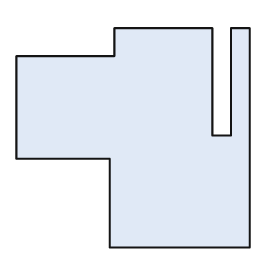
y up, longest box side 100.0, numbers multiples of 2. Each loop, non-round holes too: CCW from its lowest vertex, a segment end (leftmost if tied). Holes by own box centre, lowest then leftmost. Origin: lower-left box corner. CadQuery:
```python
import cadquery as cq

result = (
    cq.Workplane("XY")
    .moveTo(40.0, 0.0)
    .lineTo(100.0, 0.0)
    .lineTo(100.0, 94.0)
    .lineTo(92.0, 94.0)
    .lineTo(92.0, 48.0)
    .lineTo(84.0, 48.0)
    .lineTo(84.0, 94.0)
    .lineTo(42.0, 94.0)
    .lineTo(42.0, 82.0)
    .lineTo(0.0, 82.0)
    .lineTo(0.0, 38.0)
    .lineTo(40.0, 38.0)
    .close()
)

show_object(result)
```